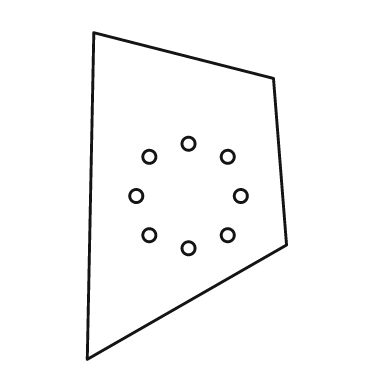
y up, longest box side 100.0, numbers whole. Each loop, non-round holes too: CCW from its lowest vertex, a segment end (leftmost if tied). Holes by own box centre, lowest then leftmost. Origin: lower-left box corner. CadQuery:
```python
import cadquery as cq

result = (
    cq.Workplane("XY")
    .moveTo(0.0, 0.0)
    .lineTo(61.0, 35.0)
    .lineTo(57.0, 86.0)
    .lineTo(2.0, 100.0)
    .close()
    .moveTo(31.0, 34.0)
    .circle(2.0)
    .moveTo(19.0, 38.0)
    .circle(2.0)
    .moveTo(43.0, 38.0)
    .circle(2.0)
    .moveTo(15.0, 50.0)
    .circle(2.0)
    .moveTo(47.0, 50.0)
    .circle(2.0)
    .moveTo(19.0, 62.0)
    .circle(2.0)
    .moveTo(43.0, 62.0)
    .circle(2.0)
    .moveTo(31.0, 66.0)
    .circle(2.0)
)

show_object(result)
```